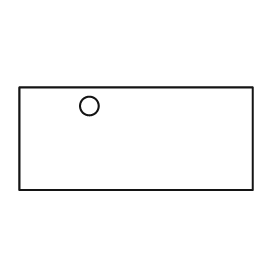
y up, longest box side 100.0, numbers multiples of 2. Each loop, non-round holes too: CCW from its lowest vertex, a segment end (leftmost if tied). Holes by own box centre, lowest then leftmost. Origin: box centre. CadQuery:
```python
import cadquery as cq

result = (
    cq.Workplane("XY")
    .moveTo(-50.0, -22.0)
    .lineTo(50.0, -22.0)
    .lineTo(50.0, 22.0)
    .lineTo(-50.0, 22.0)
    .close()
    .moveTo(-20.0, 14.0)
    .circle(4.0)
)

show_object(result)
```